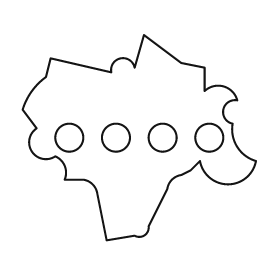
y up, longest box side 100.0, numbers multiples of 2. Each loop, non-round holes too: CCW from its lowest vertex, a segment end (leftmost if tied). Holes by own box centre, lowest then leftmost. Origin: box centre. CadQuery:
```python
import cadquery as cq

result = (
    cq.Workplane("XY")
    .moveTo(-14.0, -44.0)
    .lineTo(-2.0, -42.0)
    .threePointArc((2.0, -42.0), (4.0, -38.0))
    .lineTo(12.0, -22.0)
    .threePointArc((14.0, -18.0), (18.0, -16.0))
    .lineTo(22.0, -14.0)
    .lineTo(26.0, -10.0)
    .threePointArc((38.0, -20.0), (50.0, -10.0))
    .threePointArc((42.0, -4.0), (40.0, 6.0))
    .threePointArc((36.0, 12.0), (42.0, 16.0))
    .threePointArc((36.0, 22.0), (28.0, 20.0))
    .lineTo(28.0, 30.0)
    .lineTo(18.0, 32.0)
    .lineTo(2.0, 44.0)
    .lineTo(-2.0, 30.0)
    .threePointArc((-8.0, 34.0), (-12.0, 28.0))
    .lineTo(-38.0, 34.0)
    .lineTo(-40.0, 26.0)
    .threePointArc((-46.0, 20.0), (-50.0, 12.0))
    .lineTo(-44.0, 4.0)
    .threePointArc((-46.0, -6.0), (-36.0, -8.0))
    .threePointArc((-32.0, -12.0), (-32.0, -18.0))
    .lineTo(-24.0, -18.0)
    .threePointArc((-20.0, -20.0), (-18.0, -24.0))
    .close()
    .moveTo(-30.0, 0.0)
    .circle(6.0)
    .moveTo(-10.0, 0.0)
    .circle(6.0)
    .moveTo(10.0, 0.0)
    .circle(6.0)
    .moveTo(30.0, 0.0)
    .circle(6.0)
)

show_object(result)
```